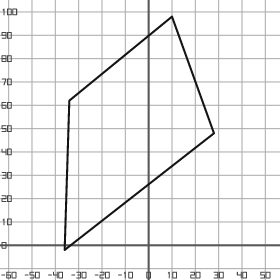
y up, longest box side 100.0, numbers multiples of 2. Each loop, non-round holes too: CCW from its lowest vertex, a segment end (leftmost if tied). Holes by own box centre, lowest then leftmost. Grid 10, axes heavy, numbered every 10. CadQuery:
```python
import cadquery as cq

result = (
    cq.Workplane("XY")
    .moveTo(-36.0, -2.0)
    .lineTo(28.0, 48.0)
    .lineTo(10.0, 98.0)
    .lineTo(-34.0, 62.0)
    .close()
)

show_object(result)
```